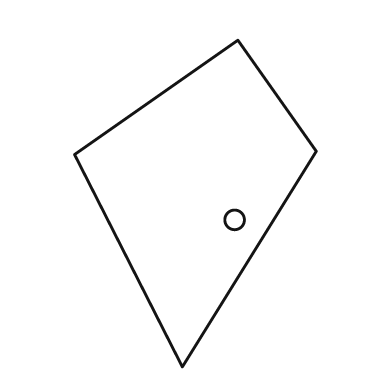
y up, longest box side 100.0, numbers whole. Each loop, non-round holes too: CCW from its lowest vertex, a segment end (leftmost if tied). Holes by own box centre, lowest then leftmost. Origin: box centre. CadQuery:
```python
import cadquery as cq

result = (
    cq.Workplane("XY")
    .moveTo(-4.0, -50.0)
    .lineTo(37.0, 16.0)
    .lineTo(13.0, 50.0)
    .lineTo(-37.0, 15.0)
    .close()
    .moveTo(12.0, -5.0)
    .circle(3.0)
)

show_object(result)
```